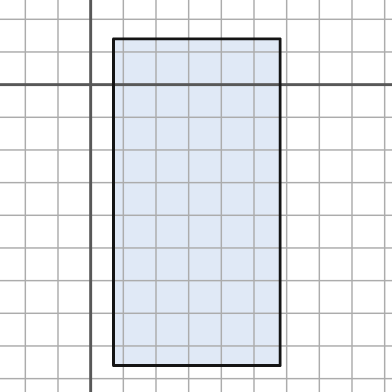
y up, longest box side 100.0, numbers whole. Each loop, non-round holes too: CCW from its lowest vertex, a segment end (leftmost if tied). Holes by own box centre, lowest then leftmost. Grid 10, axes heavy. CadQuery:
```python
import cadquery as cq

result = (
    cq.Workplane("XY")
    .moveTo(7.0, -86.0)
    .lineTo(58.0, -86.0)
    .lineTo(58.0, 14.0)
    .lineTo(7.0, 14.0)
    .close()
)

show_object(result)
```